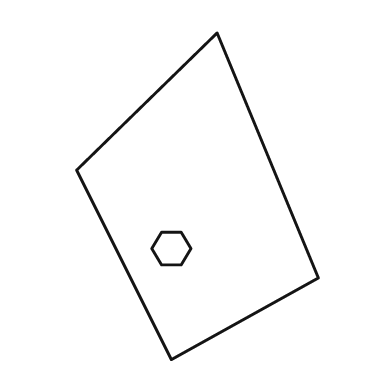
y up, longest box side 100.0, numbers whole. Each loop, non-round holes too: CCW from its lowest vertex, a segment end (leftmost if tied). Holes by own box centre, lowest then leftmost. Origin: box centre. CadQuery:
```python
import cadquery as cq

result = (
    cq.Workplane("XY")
    .moveTo(-8.0, -50.0)
    .lineTo(37.0, -25.0)
    .lineTo(6.0, 50.0)
    .lineTo(-37.0, 8.0)
    .close()
    .moveTo(-11.0, -21.0)
    .lineTo(-5.0, -21.0)
    .lineTo(-2.0, -16.0)
    .lineTo(-5.0, -11.0)
    .lineTo(-11.0, -11.0)
    .lineTo(-14.0, -16.0)
    .close()
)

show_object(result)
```